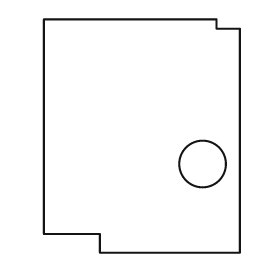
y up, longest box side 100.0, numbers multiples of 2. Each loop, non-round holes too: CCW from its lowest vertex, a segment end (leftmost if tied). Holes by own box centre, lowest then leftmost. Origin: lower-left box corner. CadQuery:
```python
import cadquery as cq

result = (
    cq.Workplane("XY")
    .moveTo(24.0, 0.0)
    .lineTo(84.0, 0.0)
    .lineTo(84.0, 96.0)
    .lineTo(74.0, 96.0)
    .lineTo(74.0, 100.0)
    .lineTo(0.0, 100.0)
    .lineTo(0.0, 8.0)
    .lineTo(24.0, 8.0)
    .close()
    .moveTo(68.0, 38.0)
    .circle(10.0)
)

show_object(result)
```